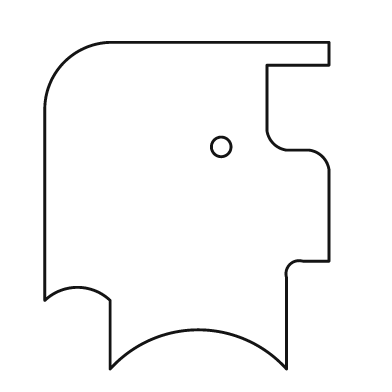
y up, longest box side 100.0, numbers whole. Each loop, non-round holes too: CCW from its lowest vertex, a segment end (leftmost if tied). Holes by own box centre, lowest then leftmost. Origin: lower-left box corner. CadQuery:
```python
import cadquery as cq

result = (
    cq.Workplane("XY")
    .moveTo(20.0, 0.0)
    .threePointArc((47.0, 12.0), (74.0, 0.0))
    .lineTo(74.0, 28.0)
    .threePointArc((75.0, 32.0), (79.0, 33.0))
    .lineTo(87.0, 33.0)
    .lineTo(87.0, 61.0)
    .threePointArc((85.0, 65.0), (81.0, 67.0))
    .lineTo(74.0, 67.0)
    .threePointArc((70.0, 69.0), (68.0, 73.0))
    .lineTo(68.0, 93.0)
    .lineTo(87.0, 93.0)
    .lineTo(87.0, 100.0)
    .lineTo(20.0, 100.0)
    .threePointArc((6.0, 94.0), (0.0, 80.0))
    .lineTo(0.0, 21.0)
    .threePointArc((10.0, 25.0), (20.0, 21.0))
    .close()
    .moveTo(54.0, 68.0)
    .circle(3.0)
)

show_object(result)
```